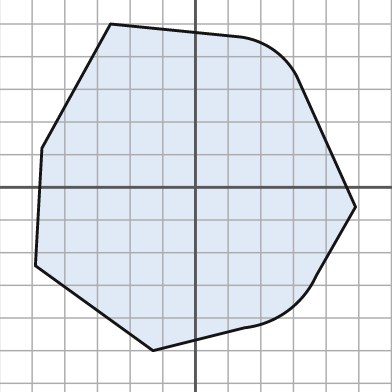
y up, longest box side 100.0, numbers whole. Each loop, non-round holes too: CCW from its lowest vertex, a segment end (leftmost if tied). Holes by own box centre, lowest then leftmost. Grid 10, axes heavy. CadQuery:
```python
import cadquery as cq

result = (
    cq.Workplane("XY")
    .moveTo(-13.0, -50.0)
    .lineTo(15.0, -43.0)
    .threePointArc((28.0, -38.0), (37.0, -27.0))
    .lineTo(49.0, -6.0)
    .lineTo(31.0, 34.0)
    .threePointArc((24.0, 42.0), (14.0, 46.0))
    .lineTo(-26.0, 50.0)
    .lineTo(-47.0, 12.0)
    .lineTo(-49.0, -24.0)
    .close()
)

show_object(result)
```